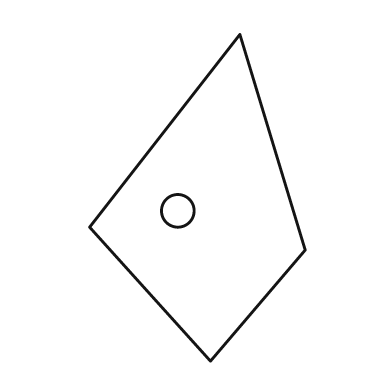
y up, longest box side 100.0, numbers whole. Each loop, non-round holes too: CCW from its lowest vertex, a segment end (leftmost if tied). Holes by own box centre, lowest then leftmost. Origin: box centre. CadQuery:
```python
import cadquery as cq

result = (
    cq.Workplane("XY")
    .moveTo(4.0, -50.0)
    .lineTo(33.0, -16.0)
    .lineTo(13.0, 50.0)
    .lineTo(-33.0, -9.0)
    .close()
    .moveTo(-6.0, -4.0)
    .circle(5.0)
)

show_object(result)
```